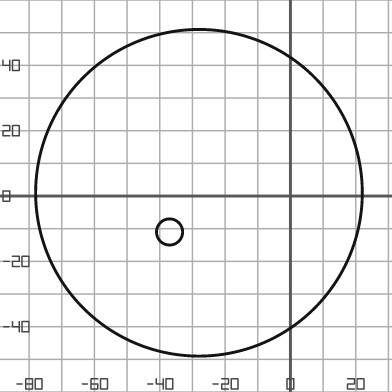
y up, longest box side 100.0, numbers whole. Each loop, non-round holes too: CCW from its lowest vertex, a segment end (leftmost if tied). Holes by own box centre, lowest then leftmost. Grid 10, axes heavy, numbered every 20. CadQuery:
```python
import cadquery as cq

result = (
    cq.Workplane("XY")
    .moveTo(-28.0, 1.0)
    .circle(50.0)
    .moveTo(-37.0, -11.0)
    .circle(4.0)
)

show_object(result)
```